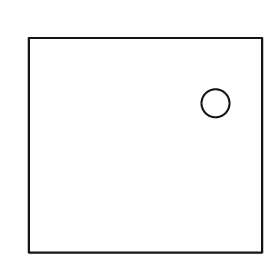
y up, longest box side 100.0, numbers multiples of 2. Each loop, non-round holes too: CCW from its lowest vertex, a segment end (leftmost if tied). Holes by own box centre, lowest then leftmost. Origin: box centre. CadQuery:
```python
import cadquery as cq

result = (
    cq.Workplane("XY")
    .moveTo(-50.0, -46.0)
    .lineTo(50.0, -46.0)
    .lineTo(50.0, 46.0)
    .lineTo(-50.0, 46.0)
    .close()
    .moveTo(30.0, 18.0)
    .circle(6.0)
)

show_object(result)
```